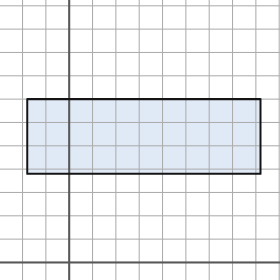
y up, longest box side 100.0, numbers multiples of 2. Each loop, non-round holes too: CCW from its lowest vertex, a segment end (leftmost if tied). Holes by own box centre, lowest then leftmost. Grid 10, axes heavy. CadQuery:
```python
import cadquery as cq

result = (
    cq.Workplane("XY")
    .moveTo(-18.0, 38.0)
    .lineTo(82.0, 38.0)
    .lineTo(82.0, 70.0)
    .lineTo(-18.0, 70.0)
    .close()
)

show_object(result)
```